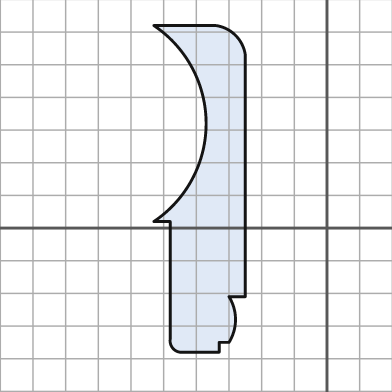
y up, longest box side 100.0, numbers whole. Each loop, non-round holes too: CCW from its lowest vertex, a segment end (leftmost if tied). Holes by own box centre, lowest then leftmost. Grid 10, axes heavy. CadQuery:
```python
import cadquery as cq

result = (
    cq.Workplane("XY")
    .moveTo(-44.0, -38.0)
    .lineTo(-33.0, -38.0)
    .lineTo(-33.0, -35.0)
    .lineTo(-30.0, -35.0)
    .threePointArc((-28.0, -28.0), (-30.0, -21.0))
    .lineTo(-25.0, -21.0)
    .lineTo(-25.0, 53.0)
    .threePointArc((-28.0, 59.0), (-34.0, 62.0))
    .lineTo(-53.0, 62.0)
    .threePointArc((-37.0, 32.0), (-53.0, 2.0))
    .lineTo(-48.0, 2.0)
    .lineTo(-48.0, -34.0)
    .threePointArc((-47.0, -37.0), (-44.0, -38.0))
    .close()
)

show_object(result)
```